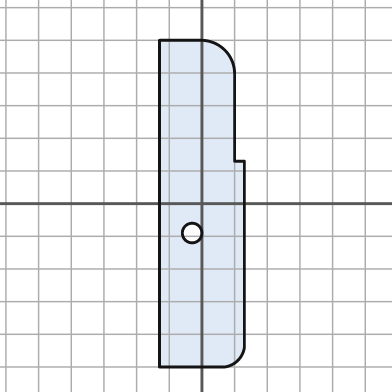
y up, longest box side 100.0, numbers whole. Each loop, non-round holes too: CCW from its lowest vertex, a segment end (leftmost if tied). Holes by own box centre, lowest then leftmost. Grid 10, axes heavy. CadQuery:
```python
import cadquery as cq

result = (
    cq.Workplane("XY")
    .moveTo(-13.0, -50.0)
    .lineTo(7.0, -50.0)
    .threePointArc((11.0, -48.0), (13.0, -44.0))
    .lineTo(13.0, 13.0)
    .lineTo(10.0, 13.0)
    .lineTo(10.0, 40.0)
    .threePointArc((7.0, 47.0), (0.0, 50.0))
    .lineTo(-13.0, 50.0)
    .close()
    .moveTo(-3.0, -9.0)
    .circle(3.0)
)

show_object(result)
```